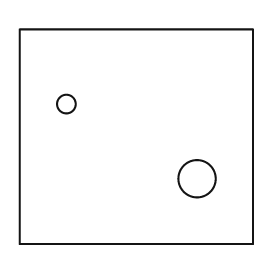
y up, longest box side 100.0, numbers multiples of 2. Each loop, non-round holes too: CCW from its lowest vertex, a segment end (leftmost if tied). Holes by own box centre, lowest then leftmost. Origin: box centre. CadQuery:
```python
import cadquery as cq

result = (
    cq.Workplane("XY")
    .moveTo(-50.0, -46.0)
    .lineTo(50.0, -46.0)
    .lineTo(50.0, 46.0)
    .lineTo(-50.0, 46.0)
    .close()
    .moveTo(26.0, -18.0)
    .circle(8.0)
    .moveTo(-30.0, 14.0)
    .circle(4.0)
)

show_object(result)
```